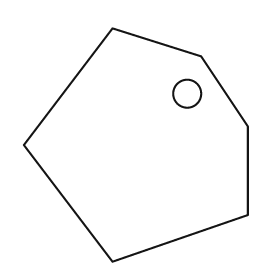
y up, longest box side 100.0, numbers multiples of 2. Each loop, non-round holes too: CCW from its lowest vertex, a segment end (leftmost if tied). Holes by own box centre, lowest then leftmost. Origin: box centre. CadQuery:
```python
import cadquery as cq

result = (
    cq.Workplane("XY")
    .moveTo(-10.0, -50.0)
    .lineTo(48.0, -30.0)
    .lineTo(48.0, 8.0)
    .lineTo(28.0, 38.0)
    .lineTo(-10.0, 50.0)
    .lineTo(-48.0, 0.0)
    .close()
    .moveTo(22.0, 22.0)
    .circle(6.0)
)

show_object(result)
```